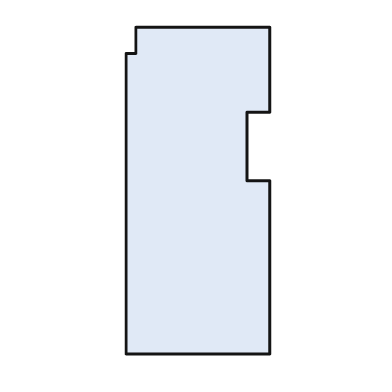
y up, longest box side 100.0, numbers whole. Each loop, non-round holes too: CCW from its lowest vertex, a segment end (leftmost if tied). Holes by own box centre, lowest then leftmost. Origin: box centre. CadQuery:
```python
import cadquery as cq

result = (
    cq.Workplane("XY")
    .moveTo(-22.0, -50.0)
    .lineTo(22.0, -50.0)
    .lineTo(22.0, 3.0)
    .lineTo(15.0, 3.0)
    .lineTo(15.0, 24.0)
    .lineTo(22.0, 24.0)
    .lineTo(22.0, 50.0)
    .lineTo(-19.0, 50.0)
    .lineTo(-19.0, 42.0)
    .lineTo(-22.0, 42.0)
    .close()
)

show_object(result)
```